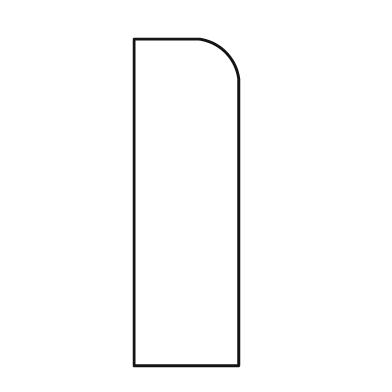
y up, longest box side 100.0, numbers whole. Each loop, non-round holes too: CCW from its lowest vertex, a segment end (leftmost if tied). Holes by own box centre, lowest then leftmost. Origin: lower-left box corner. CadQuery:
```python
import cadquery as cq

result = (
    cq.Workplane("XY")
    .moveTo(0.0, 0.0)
    .lineTo(32.0, 0.0)
    .lineTo(32.0, 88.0)
    .threePointArc((28.0, 96.0), (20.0, 100.0))
    .lineTo(0.0, 100.0)
    .close()
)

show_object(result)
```